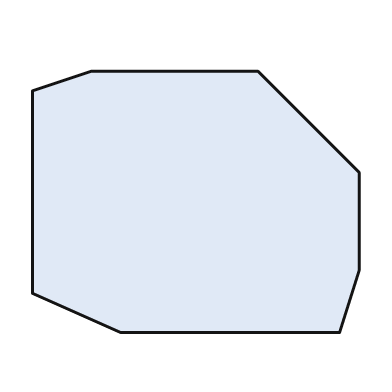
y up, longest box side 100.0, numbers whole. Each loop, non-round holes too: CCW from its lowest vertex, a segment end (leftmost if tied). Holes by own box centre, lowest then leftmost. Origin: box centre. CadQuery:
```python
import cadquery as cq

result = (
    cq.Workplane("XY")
    .moveTo(-23.0, -40.0)
    .lineTo(44.0, -40.0)
    .lineTo(50.0, -21.0)
    .lineTo(50.0, 9.0)
    .lineTo(19.0, 40.0)
    .lineTo(-32.0, 40.0)
    .lineTo(-50.0, 34.0)
    .lineTo(-50.0, -28.0)
    .close()
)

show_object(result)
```